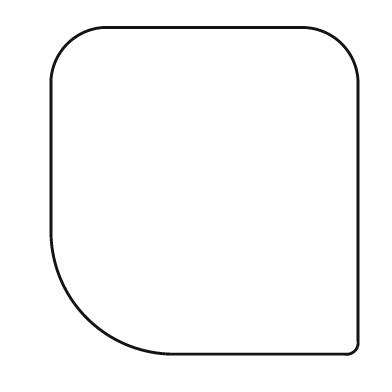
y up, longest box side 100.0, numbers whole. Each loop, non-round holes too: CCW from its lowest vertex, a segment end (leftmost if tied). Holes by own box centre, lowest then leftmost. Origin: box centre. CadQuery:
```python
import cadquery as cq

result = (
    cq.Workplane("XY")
    .moveTo(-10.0, -50.0)
    .lineTo(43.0, -50.0)
    .threePointArc((46.0, -49.0), (47.0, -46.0))
    .lineTo(47.0, 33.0)
    .threePointArc((42.0, 45.0), (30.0, 50.0))
    .lineTo(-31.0, 50.0)
    .threePointArc((-42.0, 45.0), (-47.0, 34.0))
    .lineTo(-47.0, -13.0)
    .threePointArc((-36.0, -39.0), (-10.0, -50.0))
    .close()
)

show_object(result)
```